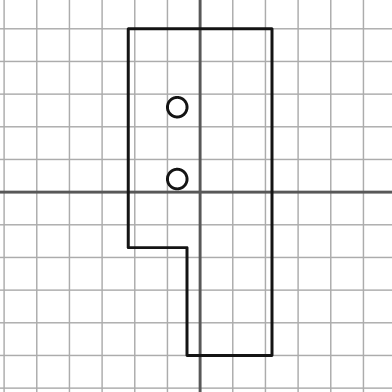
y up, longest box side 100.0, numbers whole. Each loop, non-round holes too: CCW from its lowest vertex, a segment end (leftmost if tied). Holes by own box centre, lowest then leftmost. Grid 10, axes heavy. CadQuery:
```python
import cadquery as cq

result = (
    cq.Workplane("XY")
    .moveTo(-4.0, -50.0)
    .lineTo(22.0, -50.0)
    .lineTo(22.0, 50.0)
    .lineTo(-22.0, 50.0)
    .lineTo(-22.0, -17.0)
    .lineTo(-4.0, -17.0)
    .close()
    .moveTo(-7.0, 4.0)
    .circle(3.0)
    .moveTo(-7.0, 26.0)
    .circle(3.0)
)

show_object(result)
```